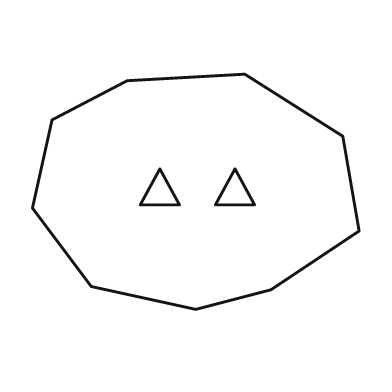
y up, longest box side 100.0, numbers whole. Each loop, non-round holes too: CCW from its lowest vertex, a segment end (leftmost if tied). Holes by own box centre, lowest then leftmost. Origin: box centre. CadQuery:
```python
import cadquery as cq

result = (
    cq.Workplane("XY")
    .moveTo(0.0, -36.0)
    .lineTo(23.0, -30.0)
    .lineTo(50.0, -12.0)
    .lineTo(45.0, 17.0)
    .lineTo(15.0, 36.0)
    .lineTo(-21.0, 34.0)
    .lineTo(-44.0, 22.0)
    .lineTo(-50.0, -5.0)
    .lineTo(-32.0, -29.0)
    .close()
    .moveTo(-17.0, -4.0)
    .lineTo(-5.0, -4.0)
    .lineTo(-11.0, 7.0)
    .close()
    .moveTo(6.0, -4.0)
    .lineTo(18.0, -4.0)
    .lineTo(12.0, 7.0)
    .close()
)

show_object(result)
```